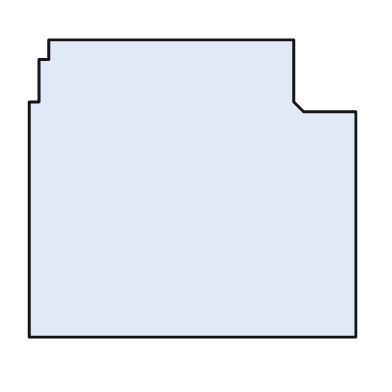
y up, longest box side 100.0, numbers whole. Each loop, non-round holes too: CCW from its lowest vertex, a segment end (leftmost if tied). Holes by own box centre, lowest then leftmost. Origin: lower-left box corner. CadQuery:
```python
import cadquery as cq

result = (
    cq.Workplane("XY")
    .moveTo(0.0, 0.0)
    .lineTo(100.0, 0.0)
    .lineTo(100.0, 69.0)
    .lineTo(84.0, 69.0)
    .lineTo(81.0, 72.0)
    .lineTo(81.0, 91.0)
    .lineTo(6.0, 91.0)
    .lineTo(6.0, 85.0)
    .lineTo(3.0, 85.0)
    .lineTo(3.0, 72.0)
    .lineTo(0.0, 72.0)
    .close()
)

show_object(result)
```